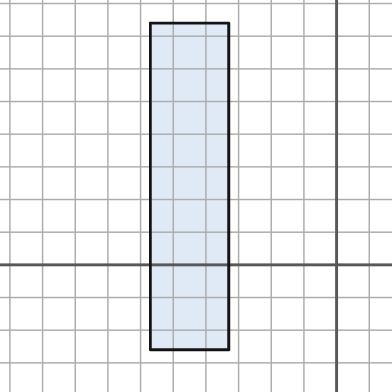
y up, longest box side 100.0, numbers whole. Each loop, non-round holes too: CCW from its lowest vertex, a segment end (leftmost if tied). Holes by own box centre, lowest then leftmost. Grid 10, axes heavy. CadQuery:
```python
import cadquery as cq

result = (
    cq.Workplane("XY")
    .moveTo(-57.0, -26.0)
    .lineTo(-33.0, -26.0)
    .lineTo(-33.0, 74.0)
    .lineTo(-57.0, 74.0)
    .close()
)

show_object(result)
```